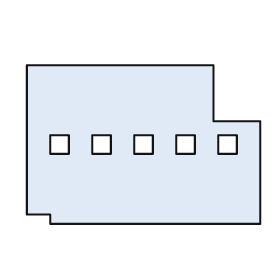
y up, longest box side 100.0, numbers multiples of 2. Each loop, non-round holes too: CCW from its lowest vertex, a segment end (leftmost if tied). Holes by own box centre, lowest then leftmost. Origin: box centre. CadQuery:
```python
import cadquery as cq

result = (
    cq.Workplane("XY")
    .moveTo(-40.0, -34.0)
    .lineTo(50.0, -34.0)
    .lineTo(50.0, 10.0)
    .lineTo(30.0, 10.0)
    .lineTo(30.0, 34.0)
    .lineTo(-50.0, 34.0)
    .lineTo(-50.0, -30.0)
    .lineTo(-40.0, -30.0)
    .close()
    .moveTo(-40.0, -4.0)
    .lineTo(-32.0, -4.0)
    .lineTo(-32.0, 4.0)
    .lineTo(-40.0, 4.0)
    .close()
    .moveTo(-22.0, -4.0)
    .lineTo(-14.0, -4.0)
    .lineTo(-14.0, 4.0)
    .lineTo(-22.0, 4.0)
    .close()
    .moveTo(-4.0, -4.0)
    .lineTo(4.0, -4.0)
    .lineTo(4.0, 4.0)
    .lineTo(-4.0, 4.0)
    .close()
    .moveTo(14.0, -4.0)
    .lineTo(22.0, -4.0)
    .lineTo(22.0, 4.0)
    .lineTo(14.0, 4.0)
    .close()
    .moveTo(32.0, -4.0)
    .lineTo(40.0, -4.0)
    .lineTo(40.0, 4.0)
    .lineTo(32.0, 4.0)
    .close()
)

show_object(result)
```